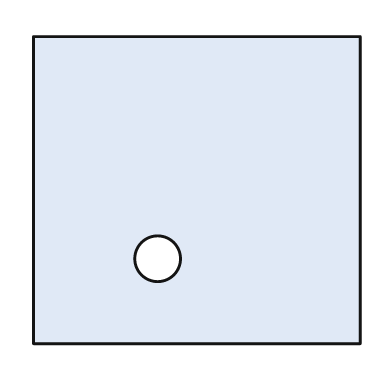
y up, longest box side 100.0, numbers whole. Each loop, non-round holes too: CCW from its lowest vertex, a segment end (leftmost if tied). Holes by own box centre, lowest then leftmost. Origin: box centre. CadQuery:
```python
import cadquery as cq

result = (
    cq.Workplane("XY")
    .moveTo(-50.0, -47.0)
    .lineTo(50.0, -47.0)
    .lineTo(50.0, 47.0)
    .lineTo(-50.0, 47.0)
    .close()
    .moveTo(-12.0, -21.0)
    .circle(7.0)
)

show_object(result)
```